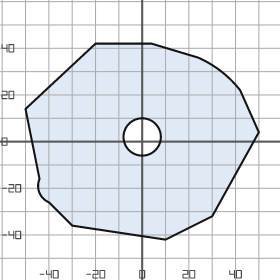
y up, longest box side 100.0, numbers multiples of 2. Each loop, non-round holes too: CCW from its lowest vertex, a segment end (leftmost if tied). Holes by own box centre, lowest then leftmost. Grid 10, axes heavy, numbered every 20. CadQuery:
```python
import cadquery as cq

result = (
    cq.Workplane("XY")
    .moveTo(10.0, -42.0)
    .lineTo(30.0, -32.0)
    .lineTo(50.0, 4.0)
    .lineTo(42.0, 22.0)
    .threePointArc((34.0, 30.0), (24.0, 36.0))
    .lineTo(4.0, 42.0)
    .lineTo(-20.0, 42.0)
    .lineTo(-50.0, 14.0)
    .lineTo(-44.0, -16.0)
    .threePointArc((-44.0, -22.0), (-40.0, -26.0))
    .lineTo(-30.0, -36.0)
    .close()
    .moveTo(0.0, 2.0)
    .circle(8.0)
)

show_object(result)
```